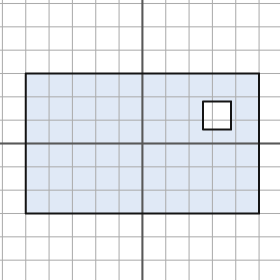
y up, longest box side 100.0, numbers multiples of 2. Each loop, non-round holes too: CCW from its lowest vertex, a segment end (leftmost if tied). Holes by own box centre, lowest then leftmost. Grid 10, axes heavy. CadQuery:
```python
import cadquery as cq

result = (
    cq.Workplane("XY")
    .moveTo(-50.0, -30.0)
    .lineTo(50.0, -30.0)
    .lineTo(50.0, 30.0)
    .lineTo(-50.0, 30.0)
    .close()
    .moveTo(26.0, 6.0)
    .lineTo(38.0, 6.0)
    .lineTo(38.0, 18.0)
    .lineTo(26.0, 18.0)
    .close()
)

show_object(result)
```